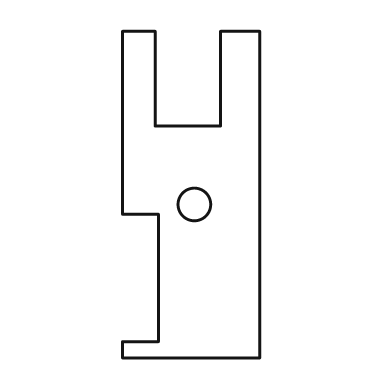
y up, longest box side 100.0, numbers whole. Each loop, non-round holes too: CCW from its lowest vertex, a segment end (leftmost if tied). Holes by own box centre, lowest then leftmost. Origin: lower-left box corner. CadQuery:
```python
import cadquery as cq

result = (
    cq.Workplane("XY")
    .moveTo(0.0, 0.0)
    .lineTo(42.0, 0.0)
    .lineTo(42.0, 100.0)
    .lineTo(30.0, 100.0)
    .lineTo(30.0, 71.0)
    .lineTo(10.0, 71.0)
    .lineTo(10.0, 100.0)
    .lineTo(0.0, 100.0)
    .lineTo(0.0, 44.0)
    .lineTo(11.0, 44.0)
    .lineTo(11.0, 5.0)
    .lineTo(0.0, 5.0)
    .close()
    .moveTo(22.0, 47.0)
    .circle(5.0)
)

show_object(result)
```